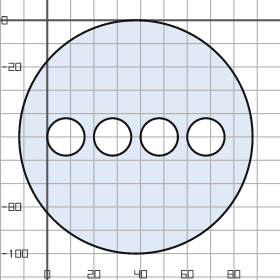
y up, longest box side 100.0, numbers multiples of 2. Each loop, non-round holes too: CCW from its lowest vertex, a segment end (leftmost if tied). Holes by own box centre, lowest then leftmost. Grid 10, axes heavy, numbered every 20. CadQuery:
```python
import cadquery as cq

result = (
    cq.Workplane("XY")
    .moveTo(38.0, -50.0)
    .circle(50.0)
    .moveTo(8.0, -50.0)
    .circle(8.0)
    .moveTo(28.0, -50.0)
    .circle(8.0)
    .moveTo(48.0, -50.0)
    .circle(8.0)
    .moveTo(68.0, -50.0)
    .circle(8.0)
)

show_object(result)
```